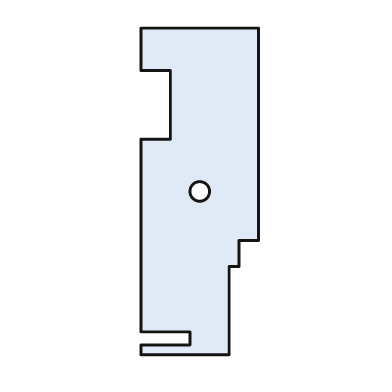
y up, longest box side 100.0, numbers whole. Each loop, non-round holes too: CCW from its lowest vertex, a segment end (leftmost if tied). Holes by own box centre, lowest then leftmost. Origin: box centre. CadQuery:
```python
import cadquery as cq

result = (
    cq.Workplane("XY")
    .moveTo(-18.0, -50.0)
    .lineTo(9.0, -50.0)
    .lineTo(9.0, -23.0)
    .lineTo(12.0, -23.0)
    .lineTo(12.0, -15.0)
    .lineTo(18.0, -15.0)
    .lineTo(18.0, 50.0)
    .lineTo(-18.0, 50.0)
    .lineTo(-18.0, 37.0)
    .lineTo(-9.0, 37.0)
    .lineTo(-9.0, 16.0)
    .lineTo(-18.0, 16.0)
    .lineTo(-18.0, -43.0)
    .lineTo(-3.0, -43.0)
    .lineTo(-3.0, -47.0)
    .lineTo(-18.0, -47.0)
    .close()
    .moveTo(0.0, 0.0)
    .circle(3.0)
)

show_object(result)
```